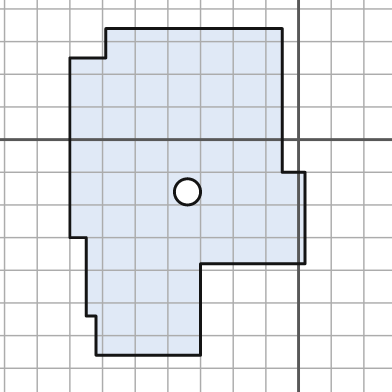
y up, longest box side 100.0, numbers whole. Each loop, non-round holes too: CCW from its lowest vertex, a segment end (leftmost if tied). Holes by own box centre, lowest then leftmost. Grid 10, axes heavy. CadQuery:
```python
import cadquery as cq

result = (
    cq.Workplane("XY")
    .moveTo(-62.0, -66.0)
    .lineTo(-30.0, -66.0)
    .lineTo(-30.0, -38.0)
    .lineTo(2.0, -38.0)
    .lineTo(2.0, -10.0)
    .lineTo(-5.0, -10.0)
    .lineTo(-5.0, 34.0)
    .lineTo(-59.0, 34.0)
    .lineTo(-59.0, 25.0)
    .lineTo(-70.0, 25.0)
    .lineTo(-70.0, -30.0)
    .lineTo(-65.0, -30.0)
    .lineTo(-65.0, -54.0)
    .lineTo(-62.0, -54.0)
    .close()
    .moveTo(-34.0, -16.0)
    .circle(4.0)
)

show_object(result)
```